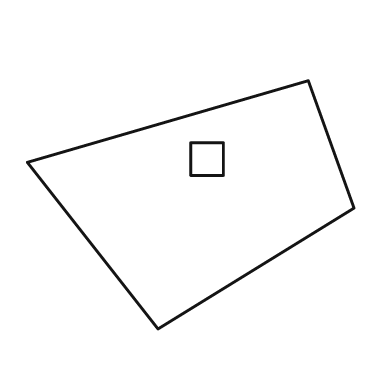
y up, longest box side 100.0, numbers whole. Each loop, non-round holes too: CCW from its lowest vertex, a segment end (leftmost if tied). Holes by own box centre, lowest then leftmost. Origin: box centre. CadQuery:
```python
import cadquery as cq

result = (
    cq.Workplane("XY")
    .moveTo(-10.0, -38.0)
    .lineTo(50.0, -1.0)
    .lineTo(36.0, 38.0)
    .lineTo(-50.0, 13.0)
    .close()
    .moveTo(0.0, 9.0)
    .lineTo(10.0, 9.0)
    .lineTo(10.0, 19.0)
    .lineTo(0.0, 19.0)
    .close()
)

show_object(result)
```